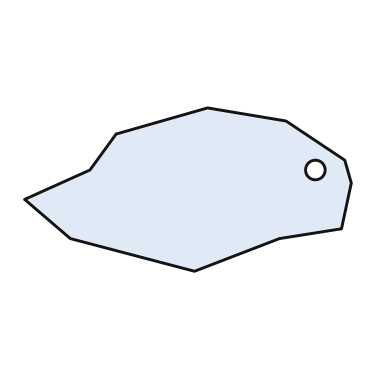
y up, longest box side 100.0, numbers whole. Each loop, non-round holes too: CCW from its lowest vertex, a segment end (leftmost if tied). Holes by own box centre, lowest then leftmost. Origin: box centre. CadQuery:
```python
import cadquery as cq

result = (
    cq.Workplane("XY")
    .moveTo(2.0, -25.0)
    .lineTo(28.0, -15.0)
    .lineTo(47.0, -12.0)
    .lineTo(50.0, 2.0)
    .lineTo(48.0, 9.0)
    .lineTo(30.0, 21.0)
    .lineTo(6.0, 25.0)
    .lineTo(-22.0, 17.0)
    .lineTo(-30.0, 6.0)
    .lineTo(-50.0, -3.0)
    .lineTo(-36.0, -15.0)
    .close()
    .moveTo(39.0, 6.0)
    .circle(3.0)
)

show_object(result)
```